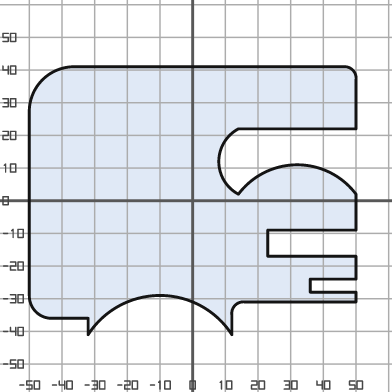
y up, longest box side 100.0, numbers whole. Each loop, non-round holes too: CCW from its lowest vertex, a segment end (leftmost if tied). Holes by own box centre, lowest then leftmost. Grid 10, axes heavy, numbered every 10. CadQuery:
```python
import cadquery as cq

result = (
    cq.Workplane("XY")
    .moveTo(-32.0, -41.0)
    .threePointArc((-10.0, -29.0), (12.0, -41.0))
    .lineTo(12.0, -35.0)
    .threePointArc((13.0, -32.0), (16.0, -31.0))
    .lineTo(50.0, -31.0)
    .lineTo(50.0, -28.0)
    .lineTo(36.0, -28.0)
    .lineTo(36.0, -24.0)
    .lineTo(50.0, -24.0)
    .lineTo(50.0, -17.0)
    .lineTo(23.0, -17.0)
    .lineTo(23.0, -9.0)
    .lineTo(50.0, -9.0)
    .lineTo(50.0, 2.0)
    .threePointArc((32.0, 11.0), (14.0, 2.0))
    .threePointArc((8.0, 12.0), (14.0, 22.0))
    .lineTo(50.0, 22.0)
    .lineTo(50.0, 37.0)
    .threePointArc((49.0, 40.0), (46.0, 41.0))
    .lineTo(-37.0, 41.0)
    .threePointArc((-46.0, 37.0), (-50.0, 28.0))
    .lineTo(-50.0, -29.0)
    .threePointArc((-48.0, -34.0), (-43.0, -36.0))
    .lineTo(-32.0, -36.0)
    .close()
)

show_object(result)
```